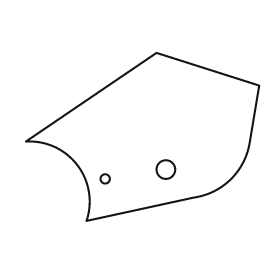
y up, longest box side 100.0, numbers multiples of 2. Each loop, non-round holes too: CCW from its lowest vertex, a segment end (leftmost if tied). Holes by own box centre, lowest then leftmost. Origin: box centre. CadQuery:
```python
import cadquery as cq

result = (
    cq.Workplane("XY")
    .moveTo(-24.0, -36.0)
    .lineTo(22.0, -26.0)
    .threePointArc((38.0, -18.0), (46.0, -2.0))
    .lineTo(50.0, 22.0)
    .lineTo(6.0, 36.0)
    .lineTo(-50.0, -2.0)
    .threePointArc((-28.0, -12.0), (-24.0, -36.0))
    .close()
    .moveTo(-16.0, -18.0)
    .circle(2.0)
    .moveTo(10.0, -14.0)
    .circle(4.0)
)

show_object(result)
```